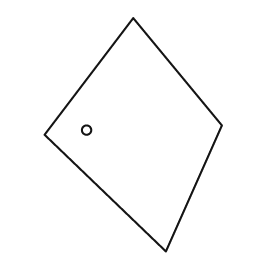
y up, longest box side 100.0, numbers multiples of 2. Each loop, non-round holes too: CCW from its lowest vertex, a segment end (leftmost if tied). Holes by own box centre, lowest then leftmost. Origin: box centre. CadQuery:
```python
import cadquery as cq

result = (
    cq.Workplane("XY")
    .moveTo(14.0, -50.0)
    .lineTo(38.0, 4.0)
    .lineTo(0.0, 50.0)
    .lineTo(-38.0, 0.0)
    .close()
    .moveTo(-20.0, 2.0)
    .circle(2.0)
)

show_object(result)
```